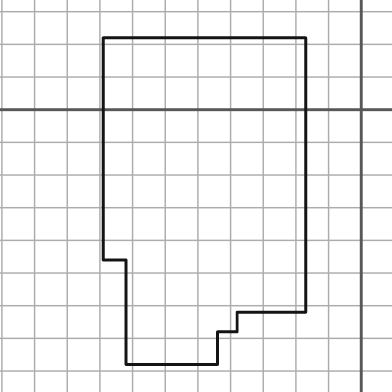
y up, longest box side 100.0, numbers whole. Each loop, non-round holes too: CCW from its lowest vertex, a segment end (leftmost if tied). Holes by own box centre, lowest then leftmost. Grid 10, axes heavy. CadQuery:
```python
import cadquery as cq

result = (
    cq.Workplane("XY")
    .moveTo(-72.0, -78.0)
    .lineTo(-44.0, -78.0)
    .lineTo(-44.0, -68.0)
    .lineTo(-38.0, -68.0)
    .lineTo(-38.0, -62.0)
    .lineTo(-17.0, -62.0)
    .lineTo(-17.0, 22.0)
    .lineTo(-79.0, 22.0)
    .lineTo(-79.0, -46.0)
    .lineTo(-72.0, -46.0)
    .close()
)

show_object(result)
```